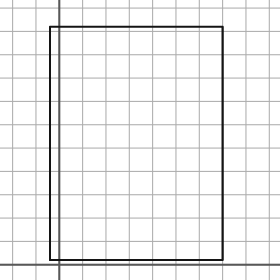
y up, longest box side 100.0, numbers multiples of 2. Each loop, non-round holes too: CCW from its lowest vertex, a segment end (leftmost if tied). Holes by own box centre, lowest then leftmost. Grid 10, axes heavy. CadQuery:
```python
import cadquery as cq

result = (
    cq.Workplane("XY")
    .moveTo(-4.0, 2.0)
    .lineTo(70.0, 2.0)
    .lineTo(70.0, 102.0)
    .lineTo(-4.0, 102.0)
    .close()
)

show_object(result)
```